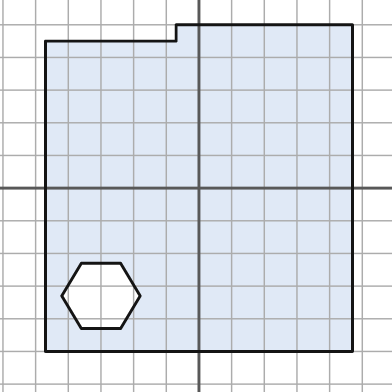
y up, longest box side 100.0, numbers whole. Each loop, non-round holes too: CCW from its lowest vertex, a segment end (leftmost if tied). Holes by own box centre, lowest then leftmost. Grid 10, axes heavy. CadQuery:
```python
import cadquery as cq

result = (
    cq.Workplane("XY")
    .moveTo(-47.0, -50.0)
    .lineTo(47.0, -50.0)
    .lineTo(47.0, 50.0)
    .lineTo(-7.0, 50.0)
    .lineTo(-7.0, 45.0)
    .lineTo(-47.0, 45.0)
    .close()
    .moveTo(-36.0, -43.0)
    .lineTo(-24.0, -43.0)
    .lineTo(-18.0, -33.0)
    .lineTo(-24.0, -23.0)
    .lineTo(-36.0, -23.0)
    .lineTo(-42.0, -33.0)
    .close()
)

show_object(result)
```